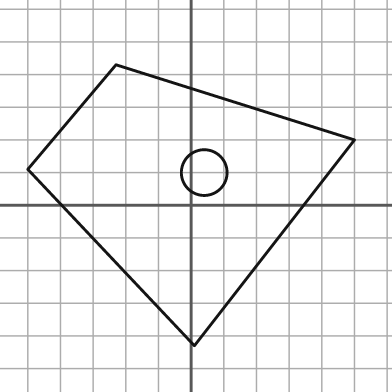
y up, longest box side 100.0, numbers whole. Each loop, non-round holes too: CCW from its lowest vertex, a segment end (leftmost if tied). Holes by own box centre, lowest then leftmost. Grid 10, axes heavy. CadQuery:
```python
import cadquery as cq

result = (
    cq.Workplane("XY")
    .moveTo(1.0, -43.0)
    .lineTo(50.0, 20.0)
    .lineTo(-23.0, 43.0)
    .lineTo(-50.0, 11.0)
    .close()
    .moveTo(4.0, 10.0)
    .circle(7.0)
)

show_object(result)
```